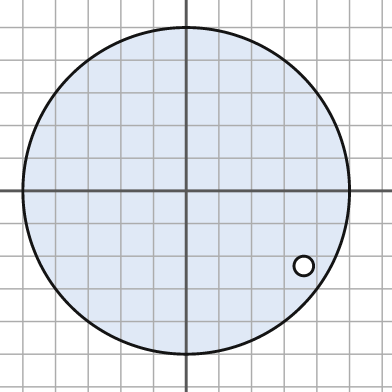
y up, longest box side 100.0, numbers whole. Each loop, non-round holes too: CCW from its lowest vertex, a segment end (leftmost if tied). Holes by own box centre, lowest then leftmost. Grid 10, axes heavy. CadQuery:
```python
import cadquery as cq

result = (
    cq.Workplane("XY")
    .moveTo(0.0, 0.0)
    .circle(50.0)
    .moveTo(36.0, -23.0)
    .circle(3.0)
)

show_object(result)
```